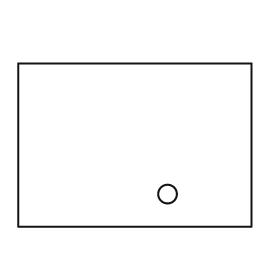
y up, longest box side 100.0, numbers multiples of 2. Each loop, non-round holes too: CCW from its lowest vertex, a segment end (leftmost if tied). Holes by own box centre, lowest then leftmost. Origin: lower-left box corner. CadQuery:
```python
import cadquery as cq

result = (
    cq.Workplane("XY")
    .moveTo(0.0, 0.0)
    .lineTo(100.0, 0.0)
    .lineTo(100.0, 70.0)
    .lineTo(0.0, 70.0)
    .close()
    .moveTo(64.0, 14.0)
    .circle(4.0)
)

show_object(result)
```